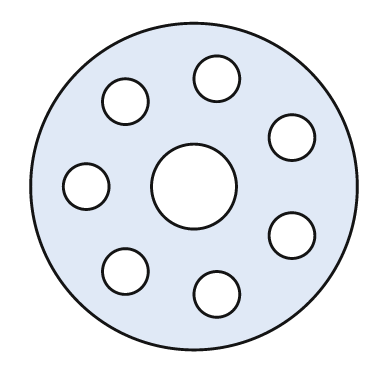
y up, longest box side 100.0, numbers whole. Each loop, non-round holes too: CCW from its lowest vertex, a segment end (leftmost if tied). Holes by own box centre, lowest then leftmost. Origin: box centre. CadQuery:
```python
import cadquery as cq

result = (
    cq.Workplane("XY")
    .moveTo(0.0, 0.0)
    .circle(50.0)
    .moveTo(7.0, -33.0)
    .circle(7.0)
    .moveTo(-21.0, -26.0)
    .circle(7.0)
    .moveTo(30.0, -15.0)
    .circle(7.0)
    .moveTo(-33.0, 0.0)
    .circle(7.0)
    .moveTo(0.0, 0.0)
    .circle(13.0)
    .moveTo(30.0, 15.0)
    .circle(7.0)
    .moveTo(-21.0, 26.0)
    .circle(7.0)
    .moveTo(7.0, 33.0)
    .circle(7.0)
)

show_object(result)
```